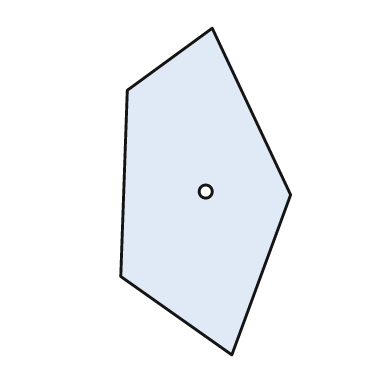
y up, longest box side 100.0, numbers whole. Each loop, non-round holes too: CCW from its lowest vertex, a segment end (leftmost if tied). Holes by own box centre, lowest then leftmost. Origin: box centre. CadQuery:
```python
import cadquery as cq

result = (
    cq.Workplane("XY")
    .moveTo(8.0, -50.0)
    .lineTo(26.0, -1.0)
    .lineTo(2.0, 50.0)
    .lineTo(-24.0, 31.0)
    .lineTo(-26.0, -26.0)
    .close()
    .moveTo(0.0, 0.0)
    .circle(2.0)
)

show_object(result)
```